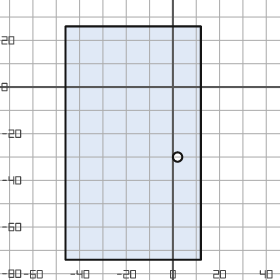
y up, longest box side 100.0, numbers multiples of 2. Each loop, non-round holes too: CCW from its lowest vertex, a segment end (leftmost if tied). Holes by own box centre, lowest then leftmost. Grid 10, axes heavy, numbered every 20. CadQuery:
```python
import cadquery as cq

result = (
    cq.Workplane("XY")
    .moveTo(-46.0, -74.0)
    .lineTo(12.0, -74.0)
    .lineTo(12.0, 26.0)
    .lineTo(-46.0, 26.0)
    .close()
    .moveTo(2.0, -30.0)
    .circle(2.0)
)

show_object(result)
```